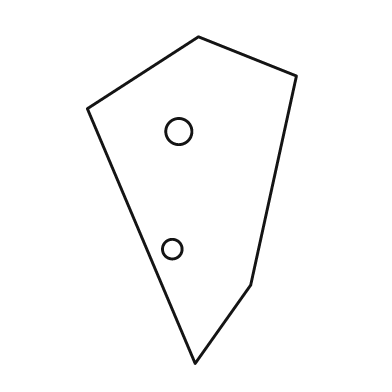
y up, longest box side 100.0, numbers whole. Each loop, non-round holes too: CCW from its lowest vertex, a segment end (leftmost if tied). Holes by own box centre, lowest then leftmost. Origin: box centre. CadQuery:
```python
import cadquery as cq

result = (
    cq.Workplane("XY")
    .moveTo(1.0, -50.0)
    .lineTo(18.0, -26.0)
    .lineTo(32.0, 38.0)
    .lineTo(2.0, 50.0)
    .lineTo(-32.0, 28.0)
    .close()
    .moveTo(-6.0, -15.0)
    .circle(3.0)
    .moveTo(-4.0, 21.0)
    .circle(4.0)
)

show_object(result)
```